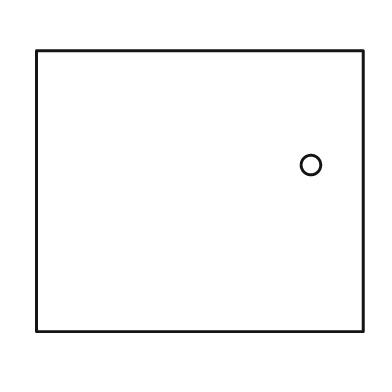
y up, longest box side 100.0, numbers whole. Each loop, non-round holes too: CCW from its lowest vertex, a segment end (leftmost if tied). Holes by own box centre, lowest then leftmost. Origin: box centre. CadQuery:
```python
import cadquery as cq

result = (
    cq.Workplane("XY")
    .moveTo(-50.0, -43.0)
    .lineTo(50.0, -43.0)
    .lineTo(50.0, 43.0)
    .lineTo(-50.0, 43.0)
    .close()
    .moveTo(34.0, 8.0)
    .circle(3.0)
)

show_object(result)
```